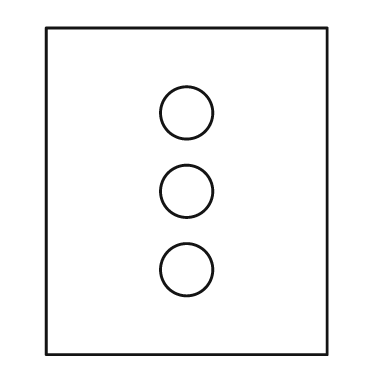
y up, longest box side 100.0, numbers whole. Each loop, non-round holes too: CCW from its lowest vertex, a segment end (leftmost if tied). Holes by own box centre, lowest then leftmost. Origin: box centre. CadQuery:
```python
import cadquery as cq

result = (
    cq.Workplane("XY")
    .moveTo(-43.0, -50.0)
    .lineTo(43.0, -50.0)
    .lineTo(43.0, 50.0)
    .lineTo(-43.0, 50.0)
    .close()
    .moveTo(0.0, -24.0)
    .circle(8.0)
    .moveTo(0.0, 0.0)
    .circle(8.0)
    .moveTo(0.0, 24.0)
    .circle(8.0)
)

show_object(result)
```